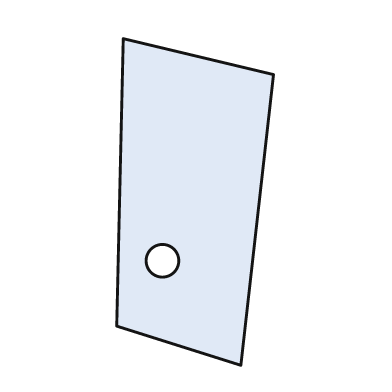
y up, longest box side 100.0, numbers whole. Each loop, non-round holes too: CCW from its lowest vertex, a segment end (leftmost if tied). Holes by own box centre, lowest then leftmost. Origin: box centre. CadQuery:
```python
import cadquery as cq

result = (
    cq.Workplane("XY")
    .moveTo(14.0, -50.0)
    .lineTo(24.0, 39.0)
    .lineTo(-22.0, 50.0)
    .lineTo(-24.0, -38.0)
    .close()
    .moveTo(-10.0, -18.0)
    .circle(5.0)
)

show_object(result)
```